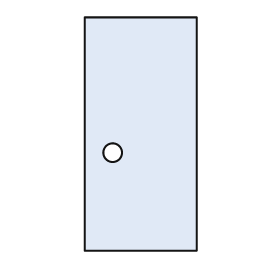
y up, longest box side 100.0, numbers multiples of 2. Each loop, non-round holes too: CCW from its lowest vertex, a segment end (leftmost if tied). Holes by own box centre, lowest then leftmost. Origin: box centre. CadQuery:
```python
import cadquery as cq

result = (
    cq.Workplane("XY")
    .moveTo(-24.0, -50.0)
    .lineTo(24.0, -50.0)
    .lineTo(24.0, 50.0)
    .lineTo(-24.0, 50.0)
    .close()
    .moveTo(-12.0, -8.0)
    .circle(4.0)
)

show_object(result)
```